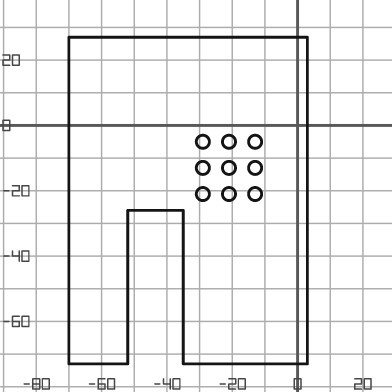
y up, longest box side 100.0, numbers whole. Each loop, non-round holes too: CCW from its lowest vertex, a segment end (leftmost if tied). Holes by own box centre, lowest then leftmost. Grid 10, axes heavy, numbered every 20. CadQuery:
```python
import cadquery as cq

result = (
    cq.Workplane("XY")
    .moveTo(-70.0, -73.0)
    .lineTo(-52.0, -73.0)
    .lineTo(-52.0, -26.0)
    .lineTo(-35.0, -26.0)
    .lineTo(-35.0, -73.0)
    .lineTo(3.0, -73.0)
    .lineTo(3.0, 27.0)
    .lineTo(-70.0, 27.0)
    .close()
    .moveTo(-29.0, -21.0)
    .circle(2.0)
    .moveTo(-21.0, -21.0)
    .circle(2.0)
    .moveTo(-13.0, -21.0)
    .circle(2.0)
    .moveTo(-29.0, -13.0)
    .circle(2.0)
    .moveTo(-21.0, -13.0)
    .circle(2.0)
    .moveTo(-13.0, -13.0)
    .circle(2.0)
    .moveTo(-29.0, -5.0)
    .circle(2.0)
    .moveTo(-21.0, -5.0)
    .circle(2.0)
    .moveTo(-13.0, -5.0)
    .circle(2.0)
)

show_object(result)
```